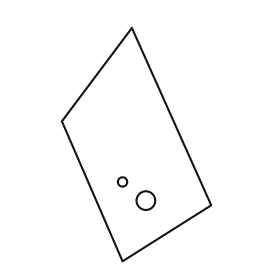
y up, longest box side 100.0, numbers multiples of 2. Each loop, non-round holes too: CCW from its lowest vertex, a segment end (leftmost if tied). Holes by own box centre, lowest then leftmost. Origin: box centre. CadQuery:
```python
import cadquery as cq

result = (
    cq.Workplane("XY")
    .moveTo(-6.0, -50.0)
    .lineTo(32.0, -26.0)
    .lineTo(-2.0, 50.0)
    .lineTo(-32.0, 10.0)
    .close()
    .moveTo(4.0, -24.0)
    .circle(4.0)
    .moveTo(-6.0, -16.0)
    .circle(2.0)
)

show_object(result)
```